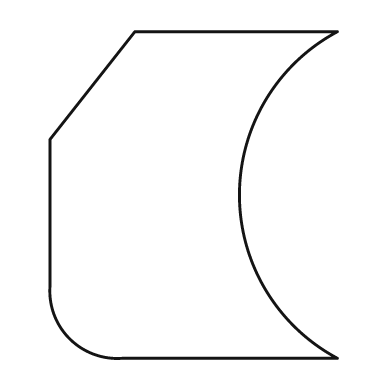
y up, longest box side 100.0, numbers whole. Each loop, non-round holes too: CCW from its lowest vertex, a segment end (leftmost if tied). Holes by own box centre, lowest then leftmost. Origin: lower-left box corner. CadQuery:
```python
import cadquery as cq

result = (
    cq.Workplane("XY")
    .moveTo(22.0, 0.0)
    .lineTo(88.0, 0.0)
    .threePointArc((58.0, 50.0), (88.0, 100.0))
    .lineTo(26.0, 100.0)
    .lineTo(0.0, 67.0)
    .lineTo(0.0, 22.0)
    .threePointArc((6.0, 6.0), (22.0, 0.0))
    .close()
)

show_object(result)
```